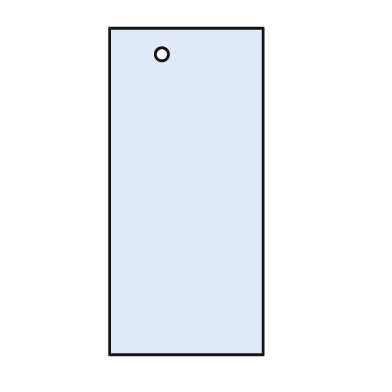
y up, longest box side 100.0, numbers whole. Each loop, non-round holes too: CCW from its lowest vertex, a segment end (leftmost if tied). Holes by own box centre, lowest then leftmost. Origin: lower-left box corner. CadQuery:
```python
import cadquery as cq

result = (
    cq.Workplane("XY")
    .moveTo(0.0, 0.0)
    .lineTo(47.0, 0.0)
    .lineTo(47.0, 100.0)
    .lineTo(0.0, 100.0)
    .close()
    .moveTo(16.0, 92.0)
    .circle(2.0)
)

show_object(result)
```